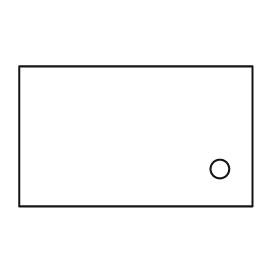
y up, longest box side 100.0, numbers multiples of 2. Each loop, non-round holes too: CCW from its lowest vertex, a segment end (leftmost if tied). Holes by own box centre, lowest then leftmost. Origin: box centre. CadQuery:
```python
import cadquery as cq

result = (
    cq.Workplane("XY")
    .moveTo(-50.0, -30.0)
    .lineTo(50.0, -30.0)
    .lineTo(50.0, 30.0)
    .lineTo(-50.0, 30.0)
    .close()
    .moveTo(36.0, -14.0)
    .circle(4.0)
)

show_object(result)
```